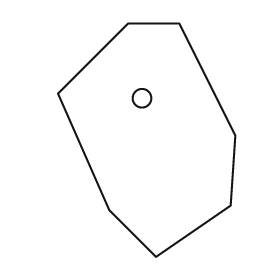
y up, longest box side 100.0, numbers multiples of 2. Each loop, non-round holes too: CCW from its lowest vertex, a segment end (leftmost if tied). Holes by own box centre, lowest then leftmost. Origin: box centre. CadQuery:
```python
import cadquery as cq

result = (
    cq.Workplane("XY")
    .moveTo(4.0, -50.0)
    .lineTo(36.0, -28.0)
    .lineTo(38.0, 2.0)
    .lineTo(14.0, 50.0)
    .lineTo(-8.0, 50.0)
    .lineTo(-38.0, 20.0)
    .lineTo(-16.0, -30.0)
    .close()
    .moveTo(-2.0, 18.0)
    .circle(4.0)
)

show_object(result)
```